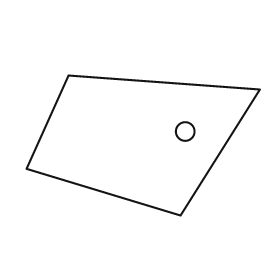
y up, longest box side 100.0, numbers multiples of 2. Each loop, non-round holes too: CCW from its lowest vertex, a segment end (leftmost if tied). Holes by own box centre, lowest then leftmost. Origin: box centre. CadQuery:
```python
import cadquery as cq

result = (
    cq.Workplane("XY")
    .moveTo(16.0, -30.0)
    .lineTo(50.0, 24.0)
    .lineTo(-32.0, 30.0)
    .lineTo(-50.0, -10.0)
    .close()
    .moveTo(18.0, 6.0)
    .circle(4.0)
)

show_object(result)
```